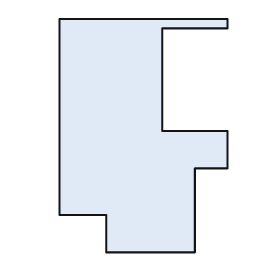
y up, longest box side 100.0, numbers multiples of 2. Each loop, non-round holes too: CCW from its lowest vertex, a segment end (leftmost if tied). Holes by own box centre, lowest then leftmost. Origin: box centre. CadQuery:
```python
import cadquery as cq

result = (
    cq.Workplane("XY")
    .moveTo(-16.0, -50.0)
    .lineTo(22.0, -50.0)
    .lineTo(22.0, -14.0)
    .lineTo(36.0, -14.0)
    .lineTo(36.0, 2.0)
    .lineTo(8.0, 2.0)
    .lineTo(8.0, 46.0)
    .lineTo(36.0, 46.0)
    .lineTo(36.0, 50.0)
    .lineTo(-36.0, 50.0)
    .lineTo(-36.0, -34.0)
    .lineTo(-16.0, -34.0)
    .close()
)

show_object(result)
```